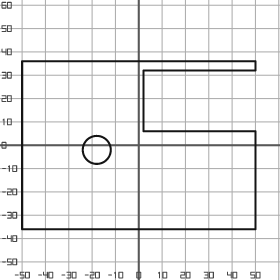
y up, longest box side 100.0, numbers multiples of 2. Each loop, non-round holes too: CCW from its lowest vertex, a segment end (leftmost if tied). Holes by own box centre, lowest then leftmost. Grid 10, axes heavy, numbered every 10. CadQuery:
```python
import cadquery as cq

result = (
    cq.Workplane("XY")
    .moveTo(-50.0, -36.0)
    .lineTo(50.0, -36.0)
    .lineTo(50.0, 6.0)
    .lineTo(2.0, 6.0)
    .lineTo(2.0, 32.0)
    .lineTo(50.0, 32.0)
    .lineTo(50.0, 36.0)
    .lineTo(-50.0, 36.0)
    .close()
    .moveTo(-18.0, -2.0)
    .circle(6.0)
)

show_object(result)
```